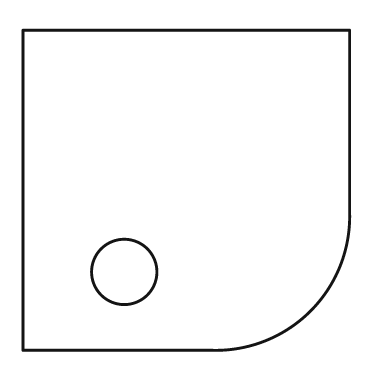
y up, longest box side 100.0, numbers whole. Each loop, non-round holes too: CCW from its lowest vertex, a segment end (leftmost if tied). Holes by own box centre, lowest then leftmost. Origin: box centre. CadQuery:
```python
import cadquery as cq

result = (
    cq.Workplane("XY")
    .moveTo(-50.0, -49.0)
    .lineTo(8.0, -49.0)
    .threePointArc((38.0, -37.0), (50.0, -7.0))
    .lineTo(50.0, 49.0)
    .lineTo(-50.0, 49.0)
    .close()
    .moveTo(-19.0, -25.0)
    .circle(10.0)
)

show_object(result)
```